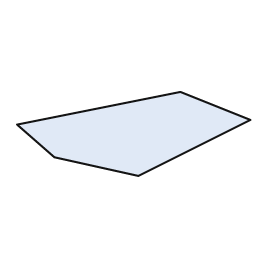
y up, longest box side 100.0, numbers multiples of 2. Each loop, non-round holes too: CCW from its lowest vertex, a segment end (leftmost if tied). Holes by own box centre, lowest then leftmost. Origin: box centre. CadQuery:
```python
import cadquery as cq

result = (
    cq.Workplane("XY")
    .moveTo(2.0, -18.0)
    .lineTo(50.0, 6.0)
    .lineTo(20.0, 18.0)
    .lineTo(-50.0, 4.0)
    .lineTo(-34.0, -10.0)
    .close()
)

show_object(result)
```